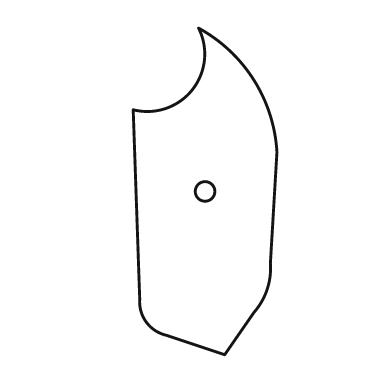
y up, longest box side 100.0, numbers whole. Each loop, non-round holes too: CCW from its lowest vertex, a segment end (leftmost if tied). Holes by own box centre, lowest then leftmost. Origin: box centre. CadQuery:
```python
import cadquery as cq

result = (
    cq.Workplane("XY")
    .moveTo(6.0, -50.0)
    .lineTo(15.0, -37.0)
    .threePointArc((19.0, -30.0), (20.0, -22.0))
    .lineTo(22.0, 12.0)
    .threePointArc((15.0, 34.0), (-2.0, 50.0))
    .threePointArc((-4.0, 31.0), (-22.0, 25.0))
    .lineTo(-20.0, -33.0)
    .threePointArc((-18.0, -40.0), (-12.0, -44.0))
    .close()
    .moveTo(0.0, 0.0)
    .circle(3.0)
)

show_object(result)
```